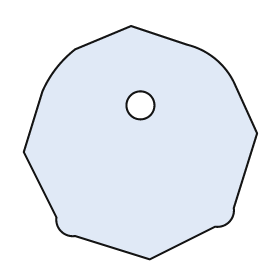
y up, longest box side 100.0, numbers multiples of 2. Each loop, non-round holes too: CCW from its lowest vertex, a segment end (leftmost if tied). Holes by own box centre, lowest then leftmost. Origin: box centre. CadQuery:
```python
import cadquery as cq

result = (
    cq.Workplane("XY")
    .moveTo(4.0, -50.0)
    .lineTo(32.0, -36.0)
    .threePointArc((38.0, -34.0), (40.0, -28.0))
    .lineTo(50.0, 4.0)
    .lineTo(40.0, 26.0)
    .threePointArc((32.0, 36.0), (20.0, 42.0))
    .lineTo(-4.0, 50.0)
    .lineTo(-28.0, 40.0)
    .threePointArc((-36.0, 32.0), (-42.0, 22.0))
    .lineTo(-50.0, -4.0)
    .lineTo(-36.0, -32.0)
    .threePointArc((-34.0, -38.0), (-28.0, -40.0))
    .close()
    .moveTo(0.0, 16.0)
    .circle(6.0)
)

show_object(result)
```